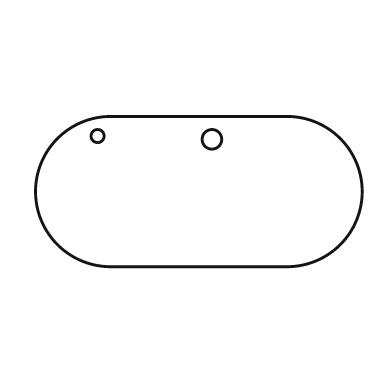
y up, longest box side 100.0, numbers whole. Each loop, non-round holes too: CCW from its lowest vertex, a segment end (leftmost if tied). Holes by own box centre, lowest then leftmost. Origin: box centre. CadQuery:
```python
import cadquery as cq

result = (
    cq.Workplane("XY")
    .moveTo(-27.0, -23.0)
    .lineTo(27.0, -23.0)
    .threePointArc((50.0, 0.0), (27.0, 23.0))
    .lineTo(-27.0, 23.0)
    .threePointArc((-50.0, 0.0), (-27.0, -23.0))
    .close()
    .moveTo(4.0, 16.0)
    .circle(3.0)
    .moveTo(-31.0, 17.0)
    .circle(2.0)
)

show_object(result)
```